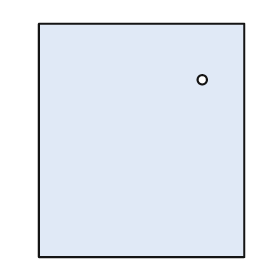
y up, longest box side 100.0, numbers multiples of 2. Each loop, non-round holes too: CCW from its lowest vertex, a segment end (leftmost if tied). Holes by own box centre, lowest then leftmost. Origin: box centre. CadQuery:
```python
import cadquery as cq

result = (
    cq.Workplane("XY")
    .moveTo(-44.0, -50.0)
    .lineTo(44.0, -50.0)
    .lineTo(44.0, 50.0)
    .lineTo(-44.0, 50.0)
    .close()
    .moveTo(26.0, 26.0)
    .circle(2.0)
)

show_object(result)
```